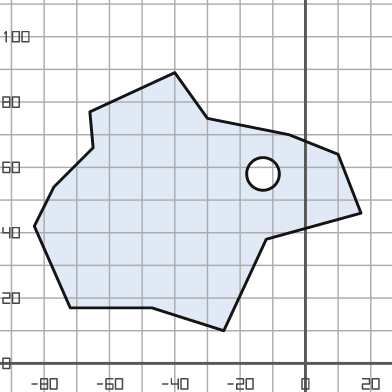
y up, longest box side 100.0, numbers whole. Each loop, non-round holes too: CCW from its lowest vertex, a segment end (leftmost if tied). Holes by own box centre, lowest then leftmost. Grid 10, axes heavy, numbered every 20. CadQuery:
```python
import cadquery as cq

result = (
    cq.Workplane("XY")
    .moveTo(-25.0, 10.0)
    .lineTo(-12.0, 38.0)
    .lineTo(17.0, 46.0)
    .lineTo(10.0, 64.0)
    .lineTo(-5.0, 70.0)
    .lineTo(-30.0, 75.0)
    .lineTo(-40.0, 89.0)
    .lineTo(-66.0, 77.0)
    .lineTo(-65.0, 66.0)
    .lineTo(-77.0, 54.0)
    .lineTo(-83.0, 42.0)
    .lineTo(-72.0, 17.0)
    .lineTo(-47.0, 17.0)
    .close()
    .moveTo(-13.0, 58.0)
    .circle(5.0)
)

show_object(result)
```